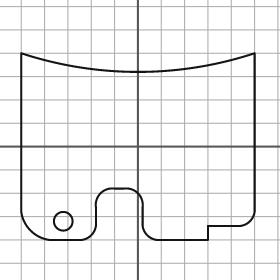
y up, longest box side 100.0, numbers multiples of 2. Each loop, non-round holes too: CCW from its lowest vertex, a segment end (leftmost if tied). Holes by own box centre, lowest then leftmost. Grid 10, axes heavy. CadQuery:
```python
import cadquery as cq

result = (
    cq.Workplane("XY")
    .moveTo(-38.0, -40.0)
    .lineTo(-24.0, -40.0)
    .threePointArc((-20.0, -38.0), (-18.0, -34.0))
    .lineTo(-18.0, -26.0)
    .threePointArc((-16.0, -20.0), (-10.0, -18.0))
    .lineTo(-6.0, -18.0)
    .threePointArc((0.0, -20.0), (2.0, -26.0))
    .lineTo(2.0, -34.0)
    .threePointArc((4.0, -38.0), (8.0, -40.0))
    .lineTo(30.0, -40.0)
    .lineTo(30.0, -34.0)
    .lineTo(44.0, -34.0)
    .threePointArc((48.0, -32.0), (50.0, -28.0))
    .lineTo(50.0, 40.0)
    .threePointArc((0.0, 32.0), (-50.0, 40.0))
    .lineTo(-50.0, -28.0)
    .threePointArc((-46.0, -36.0), (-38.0, -40.0))
    .close()
    .moveTo(-32.0, -32.0)
    .circle(4.0)
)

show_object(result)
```